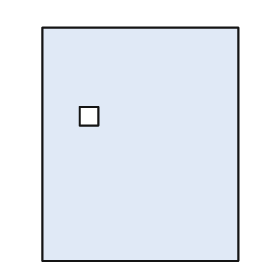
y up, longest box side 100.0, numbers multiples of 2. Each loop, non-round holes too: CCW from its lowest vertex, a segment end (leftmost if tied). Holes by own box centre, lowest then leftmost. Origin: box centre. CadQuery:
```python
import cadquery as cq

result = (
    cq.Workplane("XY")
    .moveTo(-42.0, -50.0)
    .lineTo(42.0, -50.0)
    .lineTo(42.0, 50.0)
    .lineTo(-42.0, 50.0)
    .close()
    .moveTo(-26.0, 8.0)
    .lineTo(-18.0, 8.0)
    .lineTo(-18.0, 16.0)
    .lineTo(-26.0, 16.0)
    .close()
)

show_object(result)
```